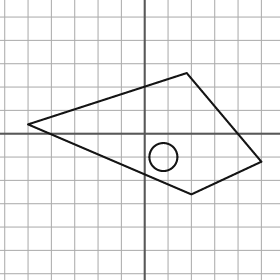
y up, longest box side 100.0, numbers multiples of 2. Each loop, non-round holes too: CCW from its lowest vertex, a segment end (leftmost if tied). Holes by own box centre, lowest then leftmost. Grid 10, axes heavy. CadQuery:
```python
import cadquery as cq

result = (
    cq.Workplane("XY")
    .moveTo(20.0, -26.0)
    .lineTo(50.0, -12.0)
    .lineTo(18.0, 26.0)
    .lineTo(-50.0, 4.0)
    .close()
    .moveTo(8.0, -10.0)
    .circle(6.0)
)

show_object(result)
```